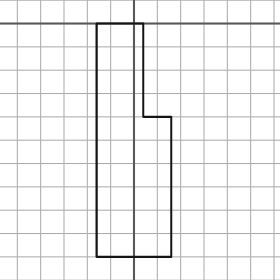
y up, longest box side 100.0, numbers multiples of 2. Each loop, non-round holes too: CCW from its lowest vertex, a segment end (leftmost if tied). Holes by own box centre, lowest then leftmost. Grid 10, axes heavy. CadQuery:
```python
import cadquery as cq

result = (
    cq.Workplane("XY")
    .moveTo(-16.0, -100.0)
    .lineTo(16.0, -100.0)
    .lineTo(16.0, -40.0)
    .lineTo(4.0, -40.0)
    .lineTo(4.0, 0.0)
    .lineTo(-16.0, 0.0)
    .close()
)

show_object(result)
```